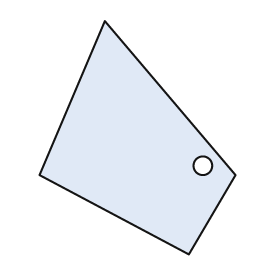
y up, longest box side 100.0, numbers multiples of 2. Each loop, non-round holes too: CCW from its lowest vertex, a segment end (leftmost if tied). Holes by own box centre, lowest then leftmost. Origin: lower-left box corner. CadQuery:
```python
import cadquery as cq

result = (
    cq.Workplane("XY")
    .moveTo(64.0, 0.0)
    .lineTo(84.0, 34.0)
    .lineTo(28.0, 100.0)
    .lineTo(0.0, 34.0)
    .close()
    .moveTo(70.0, 38.0)
    .circle(4.0)
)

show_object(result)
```